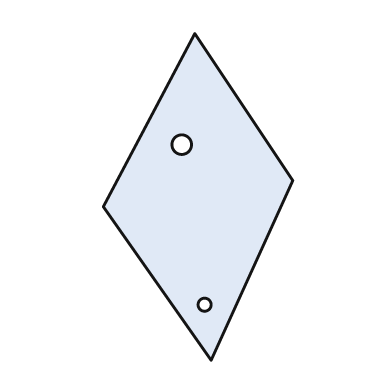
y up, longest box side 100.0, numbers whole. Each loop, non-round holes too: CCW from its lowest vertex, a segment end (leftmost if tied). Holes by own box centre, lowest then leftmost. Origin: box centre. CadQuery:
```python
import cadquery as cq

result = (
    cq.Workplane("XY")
    .moveTo(4.0, -50.0)
    .lineTo(29.0, 5.0)
    .lineTo(-1.0, 50.0)
    .lineTo(-29.0, -3.0)
    .close()
    .moveTo(2.0, -33.0)
    .circle(2.0)
    .moveTo(-5.0, 16.0)
    .circle(3.0)
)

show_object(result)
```